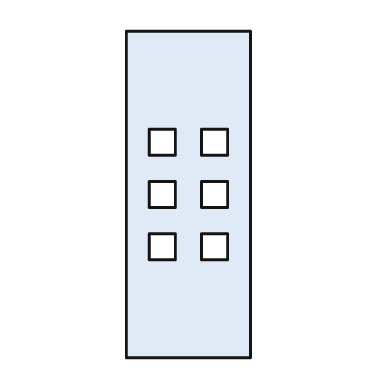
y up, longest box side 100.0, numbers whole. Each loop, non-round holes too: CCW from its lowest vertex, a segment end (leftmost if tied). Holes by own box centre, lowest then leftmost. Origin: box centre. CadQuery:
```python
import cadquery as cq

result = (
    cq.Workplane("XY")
    .moveTo(-19.0, -50.0)
    .lineTo(19.0, -50.0)
    .lineTo(19.0, 50.0)
    .lineTo(-19.0, 50.0)
    .close()
    .moveTo(-12.0, -20.0)
    .lineTo(-4.0, -20.0)
    .lineTo(-4.0, -12.0)
    .lineTo(-12.0, -12.0)
    .close()
    .moveTo(4.0, -20.0)
    .lineTo(12.0, -20.0)
    .lineTo(12.0, -12.0)
    .lineTo(4.0, -12.0)
    .close()
    .moveTo(-12.0, -4.0)
    .lineTo(-4.0, -4.0)
    .lineTo(-4.0, 4.0)
    .lineTo(-12.0, 4.0)
    .close()
    .moveTo(4.0, -4.0)
    .lineTo(12.0, -4.0)
    .lineTo(12.0, 4.0)
    .lineTo(4.0, 4.0)
    .close()
    .moveTo(-12.0, 12.0)
    .lineTo(-4.0, 12.0)
    .lineTo(-4.0, 20.0)
    .lineTo(-12.0, 20.0)
    .close()
    .moveTo(4.0, 12.0)
    .lineTo(12.0, 12.0)
    .lineTo(12.0, 20.0)
    .lineTo(4.0, 20.0)
    .close()
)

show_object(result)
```